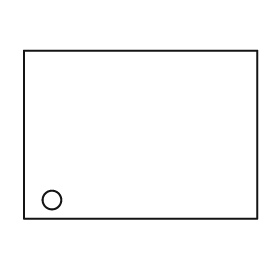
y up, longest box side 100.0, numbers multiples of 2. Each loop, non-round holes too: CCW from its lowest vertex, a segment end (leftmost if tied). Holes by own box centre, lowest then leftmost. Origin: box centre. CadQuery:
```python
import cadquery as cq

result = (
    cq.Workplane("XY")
    .moveTo(-50.0, -36.0)
    .lineTo(50.0, -36.0)
    .lineTo(50.0, 36.0)
    .lineTo(-50.0, 36.0)
    .close()
    .moveTo(-38.0, -28.0)
    .circle(4.0)
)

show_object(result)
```